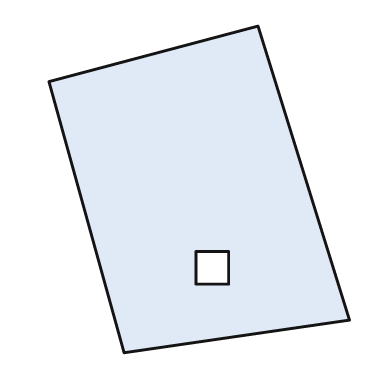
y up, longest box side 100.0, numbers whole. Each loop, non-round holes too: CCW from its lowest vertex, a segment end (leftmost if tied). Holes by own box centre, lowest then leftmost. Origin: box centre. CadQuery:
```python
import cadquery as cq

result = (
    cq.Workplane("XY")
    .moveTo(-23.0, -50.0)
    .lineTo(46.0, -40.0)
    .lineTo(18.0, 50.0)
    .lineTo(-46.0, 33.0)
    .close()
    .moveTo(-1.0, -29.0)
    .lineTo(9.0, -29.0)
    .lineTo(9.0, -19.0)
    .lineTo(-1.0, -19.0)
    .close()
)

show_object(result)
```